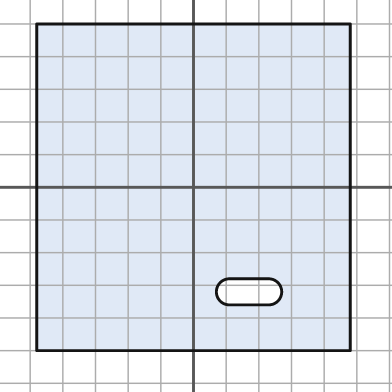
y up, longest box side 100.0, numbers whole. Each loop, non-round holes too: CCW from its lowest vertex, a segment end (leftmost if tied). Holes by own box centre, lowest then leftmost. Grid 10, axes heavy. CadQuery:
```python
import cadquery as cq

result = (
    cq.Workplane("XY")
    .moveTo(-48.0, -50.0)
    .lineTo(48.0, -50.0)
    .lineTo(48.0, 50.0)
    .lineTo(-48.0, 50.0)
    .close()
    .moveTo(11.0, -36.0)
    .lineTo(23.0, -36.0)
    .threePointArc((27.0, -32.0), (23.0, -28.0))
    .lineTo(11.0, -28.0)
    .threePointArc((7.0, -32.0), (11.0, -36.0))
    .close()
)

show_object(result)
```